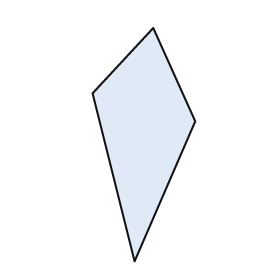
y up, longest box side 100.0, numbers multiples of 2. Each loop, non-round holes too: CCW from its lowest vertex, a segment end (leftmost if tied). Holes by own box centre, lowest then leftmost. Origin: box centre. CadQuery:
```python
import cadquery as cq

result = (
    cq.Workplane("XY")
    .moveTo(-4.0, -50.0)
    .lineTo(22.0, 10.0)
    .lineTo(4.0, 50.0)
    .lineTo(-22.0, 22.0)
    .close()
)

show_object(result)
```